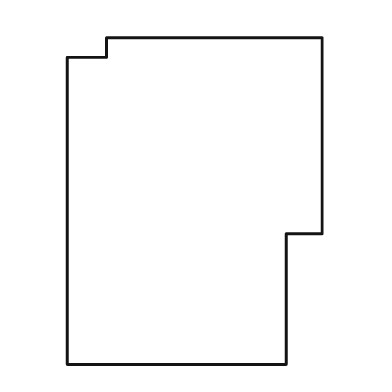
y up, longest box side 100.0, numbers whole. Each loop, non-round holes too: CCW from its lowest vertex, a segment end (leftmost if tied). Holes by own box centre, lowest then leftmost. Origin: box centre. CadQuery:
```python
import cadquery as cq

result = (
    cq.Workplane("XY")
    .moveTo(-39.0, -50.0)
    .lineTo(28.0, -50.0)
    .lineTo(28.0, -10.0)
    .lineTo(39.0, -10.0)
    .lineTo(39.0, 50.0)
    .lineTo(-27.0, 50.0)
    .lineTo(-27.0, 44.0)
    .lineTo(-39.0, 44.0)
    .close()
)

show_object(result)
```